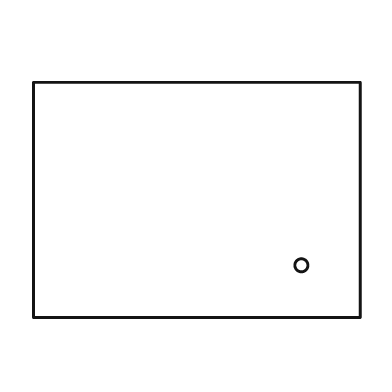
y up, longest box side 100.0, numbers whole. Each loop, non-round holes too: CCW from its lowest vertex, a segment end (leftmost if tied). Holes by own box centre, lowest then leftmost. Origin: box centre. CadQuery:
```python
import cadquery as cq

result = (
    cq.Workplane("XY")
    .moveTo(-50.0, -36.0)
    .lineTo(50.0, -36.0)
    .lineTo(50.0, 36.0)
    .lineTo(-50.0, 36.0)
    .close()
    .moveTo(32.0, -20.0)
    .circle(2.0)
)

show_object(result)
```